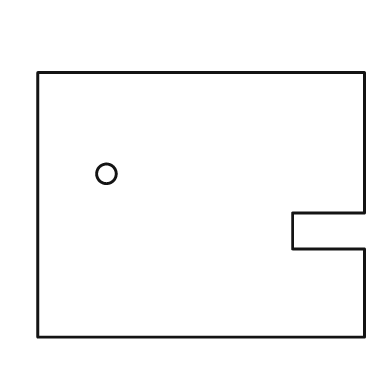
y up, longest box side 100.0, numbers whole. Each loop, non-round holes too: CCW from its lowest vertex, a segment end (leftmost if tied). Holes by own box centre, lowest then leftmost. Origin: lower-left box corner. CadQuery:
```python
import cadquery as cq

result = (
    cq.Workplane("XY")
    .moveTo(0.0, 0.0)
    .lineTo(100.0, 0.0)
    .lineTo(100.0, 27.0)
    .lineTo(78.0, 27.0)
    .lineTo(78.0, 38.0)
    .lineTo(100.0, 38.0)
    .lineTo(100.0, 81.0)
    .lineTo(0.0, 81.0)
    .close()
    .moveTo(21.0, 50.0)
    .circle(3.0)
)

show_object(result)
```